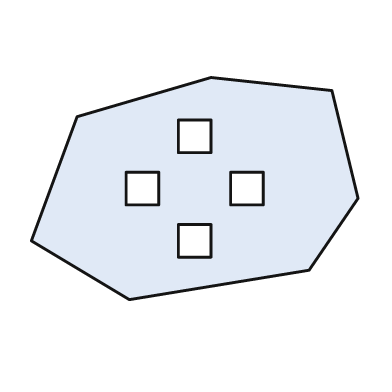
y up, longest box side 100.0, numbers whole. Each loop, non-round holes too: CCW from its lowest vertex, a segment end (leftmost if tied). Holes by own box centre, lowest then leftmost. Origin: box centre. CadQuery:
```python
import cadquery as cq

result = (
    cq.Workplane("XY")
    .moveTo(-20.0, -34.0)
    .lineTo(35.0, -25.0)
    .lineTo(50.0, -3.0)
    .lineTo(42.0, 30.0)
    .lineTo(5.0, 34.0)
    .lineTo(-36.0, 22.0)
    .lineTo(-50.0, -16.0)
    .close()
    .moveTo(-5.0, -21.0)
    .lineTo(5.0, -21.0)
    .lineTo(5.0, -11.0)
    .lineTo(-5.0, -11.0)
    .close()
    .moveTo(-21.0, -5.0)
    .lineTo(-11.0, -5.0)
    .lineTo(-11.0, 5.0)
    .lineTo(-21.0, 5.0)
    .close()
    .moveTo(11.0, -5.0)
    .lineTo(21.0, -5.0)
    .lineTo(21.0, 5.0)
    .lineTo(11.0, 5.0)
    .close()
    .moveTo(-5.0, 11.0)
    .lineTo(5.0, 11.0)
    .lineTo(5.0, 21.0)
    .lineTo(-5.0, 21.0)
    .close()
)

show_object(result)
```